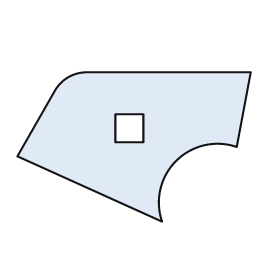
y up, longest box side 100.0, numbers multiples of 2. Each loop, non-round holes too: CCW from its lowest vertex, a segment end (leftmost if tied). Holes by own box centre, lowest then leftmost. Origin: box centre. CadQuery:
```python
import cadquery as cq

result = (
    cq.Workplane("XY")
    .moveTo(12.0, -32.0)
    .threePointArc((18.0, -6.0), (44.0, 0.0))
    .lineTo(50.0, 32.0)
    .lineTo(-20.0, 32.0)
    .threePointArc((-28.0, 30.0), (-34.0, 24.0))
    .lineTo(-50.0, -4.0)
    .close()
    .moveTo(-8.0, 2.0)
    .lineTo(4.0, 2.0)
    .lineTo(4.0, 14.0)
    .lineTo(-8.0, 14.0)
    .close()
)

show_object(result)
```